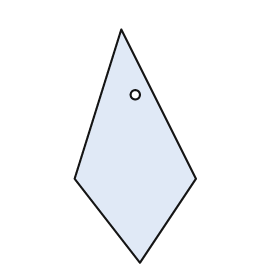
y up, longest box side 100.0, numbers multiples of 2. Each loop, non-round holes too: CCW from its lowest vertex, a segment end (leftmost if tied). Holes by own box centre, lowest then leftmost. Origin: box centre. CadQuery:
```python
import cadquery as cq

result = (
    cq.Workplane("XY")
    .moveTo(2.0, -50.0)
    .lineTo(26.0, -14.0)
    .lineTo(-6.0, 50.0)
    .lineTo(-26.0, -14.0)
    .close()
    .moveTo(0.0, 22.0)
    .circle(2.0)
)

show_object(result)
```